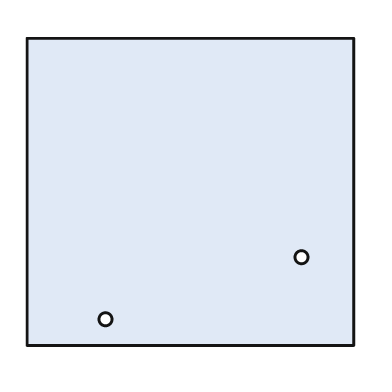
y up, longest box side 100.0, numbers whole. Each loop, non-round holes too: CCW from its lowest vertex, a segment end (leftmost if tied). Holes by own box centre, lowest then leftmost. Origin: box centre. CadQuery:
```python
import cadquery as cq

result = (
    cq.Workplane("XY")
    .moveTo(-50.0, -47.0)
    .lineTo(50.0, -47.0)
    .lineTo(50.0, 47.0)
    .lineTo(-50.0, 47.0)
    .close()
    .moveTo(-26.0, -39.0)
    .circle(2.0)
    .moveTo(34.0, -20.0)
    .circle(2.0)
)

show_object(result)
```